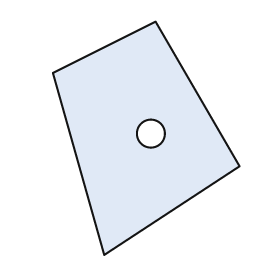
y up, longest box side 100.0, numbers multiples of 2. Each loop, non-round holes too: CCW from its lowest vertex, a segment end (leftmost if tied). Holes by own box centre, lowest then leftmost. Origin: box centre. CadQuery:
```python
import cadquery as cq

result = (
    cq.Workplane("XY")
    .moveTo(-18.0, -50.0)
    .lineTo(40.0, -12.0)
    .lineTo(4.0, 50.0)
    .lineTo(-40.0, 28.0)
    .close()
    .moveTo(2.0, 2.0)
    .circle(6.0)
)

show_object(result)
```